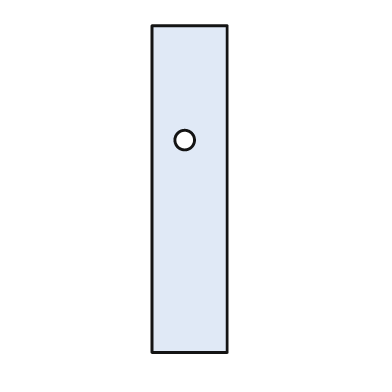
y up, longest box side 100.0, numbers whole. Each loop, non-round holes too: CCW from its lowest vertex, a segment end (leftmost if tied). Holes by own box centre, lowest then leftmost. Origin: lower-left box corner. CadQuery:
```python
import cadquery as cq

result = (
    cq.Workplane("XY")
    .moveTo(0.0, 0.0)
    .lineTo(23.0, 0.0)
    .lineTo(23.0, 100.0)
    .lineTo(0.0, 100.0)
    .close()
    .moveTo(10.0, 65.0)
    .circle(3.0)
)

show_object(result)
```